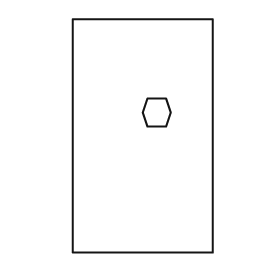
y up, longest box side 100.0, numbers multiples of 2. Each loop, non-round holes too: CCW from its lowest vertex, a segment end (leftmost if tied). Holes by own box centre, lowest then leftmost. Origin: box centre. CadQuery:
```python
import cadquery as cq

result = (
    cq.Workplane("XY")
    .moveTo(-30.0, -50.0)
    .lineTo(30.0, -50.0)
    .lineTo(30.0, 50.0)
    .lineTo(-30.0, 50.0)
    .close()
    .moveTo(2.0, 4.0)
    .lineTo(10.0, 4.0)
    .lineTo(12.0, 10.0)
    .lineTo(10.0, 16.0)
    .lineTo(2.0, 16.0)
    .lineTo(0.0, 10.0)
    .close()
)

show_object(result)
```